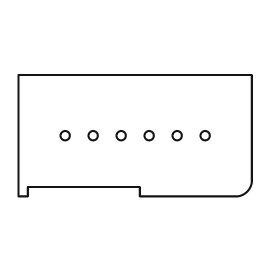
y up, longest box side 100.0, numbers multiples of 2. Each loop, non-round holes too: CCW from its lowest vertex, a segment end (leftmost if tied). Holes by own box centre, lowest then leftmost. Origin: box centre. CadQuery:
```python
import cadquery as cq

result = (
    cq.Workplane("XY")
    .moveTo(-50.0, -26.0)
    .lineTo(-46.0, -26.0)
    .lineTo(-46.0, -22.0)
    .lineTo(2.0, -22.0)
    .lineTo(2.0, -26.0)
    .lineTo(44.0, -26.0)
    .threePointArc((48.0, -24.0), (50.0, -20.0))
    .lineTo(50.0, 26.0)
    .lineTo(-50.0, 26.0)
    .close()
    .moveTo(-30.0, 0.0)
    .circle(2.0)
    .moveTo(-18.0, 0.0)
    .circle(2.0)
    .moveTo(-6.0, 0.0)
    .circle(2.0)
    .moveTo(6.0, 0.0)
    .circle(2.0)
    .moveTo(18.0, 0.0)
    .circle(2.0)
    .moveTo(30.0, 0.0)
    .circle(2.0)
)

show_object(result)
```